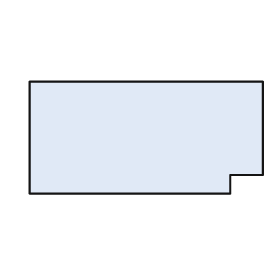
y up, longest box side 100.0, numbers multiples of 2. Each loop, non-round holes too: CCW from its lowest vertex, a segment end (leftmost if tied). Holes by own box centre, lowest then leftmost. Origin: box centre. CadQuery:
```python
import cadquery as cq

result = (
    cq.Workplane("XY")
    .moveTo(-50.0, -24.0)
    .lineTo(36.0, -24.0)
    .lineTo(36.0, -16.0)
    .lineTo(50.0, -16.0)
    .lineTo(50.0, 24.0)
    .lineTo(-50.0, 24.0)
    .close()
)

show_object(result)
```